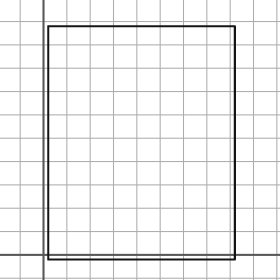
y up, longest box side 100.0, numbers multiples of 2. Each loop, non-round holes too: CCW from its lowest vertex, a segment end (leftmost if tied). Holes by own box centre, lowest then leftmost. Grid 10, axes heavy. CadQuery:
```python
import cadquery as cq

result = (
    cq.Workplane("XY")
    .moveTo(2.0, -2.0)
    .lineTo(82.0, -2.0)
    .lineTo(82.0, 98.0)
    .lineTo(2.0, 98.0)
    .close()
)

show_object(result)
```